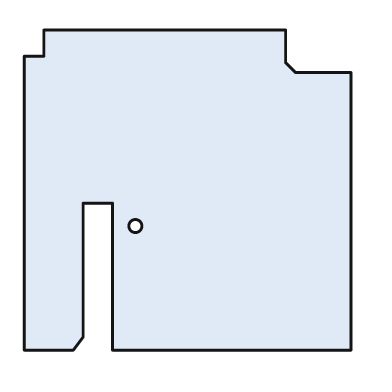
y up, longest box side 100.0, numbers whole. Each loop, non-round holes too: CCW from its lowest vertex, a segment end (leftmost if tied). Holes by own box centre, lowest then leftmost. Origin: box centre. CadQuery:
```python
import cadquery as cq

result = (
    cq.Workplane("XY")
    .moveTo(-50.0, -49.0)
    .lineTo(-35.0, -49.0)
    .lineTo(-32.0, -45.0)
    .lineTo(-32.0, -4.0)
    .lineTo(-23.0, -4.0)
    .lineTo(-23.0, -49.0)
    .lineTo(50.0, -49.0)
    .lineTo(50.0, 36.0)
    .lineTo(33.0, 36.0)
    .lineTo(30.0, 39.0)
    .lineTo(30.0, 49.0)
    .lineTo(-44.0, 49.0)
    .lineTo(-44.0, 41.0)
    .lineTo(-50.0, 41.0)
    .close()
    .moveTo(-16.0, -11.0)
    .circle(2.0)
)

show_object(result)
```